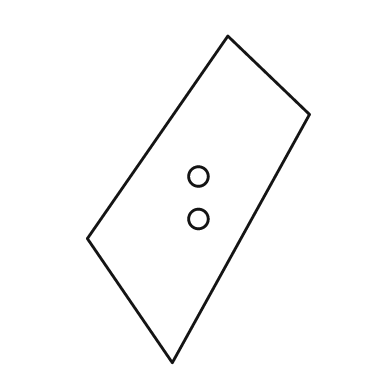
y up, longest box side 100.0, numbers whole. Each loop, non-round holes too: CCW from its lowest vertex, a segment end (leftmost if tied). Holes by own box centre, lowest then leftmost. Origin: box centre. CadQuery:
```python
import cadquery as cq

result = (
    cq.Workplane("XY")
    .moveTo(-8.0, -50.0)
    .lineTo(34.0, 26.0)
    .lineTo(9.0, 50.0)
    .lineTo(-34.0, -12.0)
    .close()
    .moveTo(0.0, -6.0)
    .circle(3.0)
    .moveTo(0.0, 7.0)
    .circle(3.0)
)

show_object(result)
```